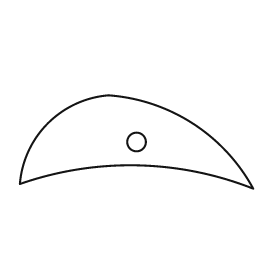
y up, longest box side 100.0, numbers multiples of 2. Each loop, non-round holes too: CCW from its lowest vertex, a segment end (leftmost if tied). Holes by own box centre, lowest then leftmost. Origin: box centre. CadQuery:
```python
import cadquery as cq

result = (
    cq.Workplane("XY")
    .moveTo(50.0, -20.0)
    .threePointArc((24.0, 8.0), (-12.0, 20.0))
    .threePointArc((-38.0, 8.0), (-50.0, -18.0))
    .threePointArc((0.0, -10.0), (50.0, -20.0))
    .close()
    .moveTo(0.0, 0.0)
    .circle(4.0)
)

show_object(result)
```